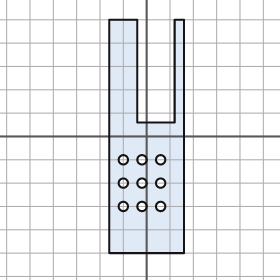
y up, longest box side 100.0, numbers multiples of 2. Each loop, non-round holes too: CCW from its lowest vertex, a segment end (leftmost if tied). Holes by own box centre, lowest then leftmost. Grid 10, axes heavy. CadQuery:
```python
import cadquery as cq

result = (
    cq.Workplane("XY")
    .moveTo(-16.0, -50.0)
    .lineTo(16.0, -50.0)
    .lineTo(16.0, 50.0)
    .lineTo(12.0, 50.0)
    .lineTo(12.0, 6.0)
    .lineTo(-4.0, 6.0)
    .lineTo(-4.0, 50.0)
    .lineTo(-16.0, 50.0)
    .close()
    .moveTo(-10.0, -30.0)
    .circle(2.0)
    .moveTo(-2.0, -30.0)
    .circle(2.0)
    .moveTo(6.0, -30.0)
    .circle(2.0)
    .moveTo(-10.0, -20.0)
    .circle(2.0)
    .moveTo(-2.0, -20.0)
    .circle(2.0)
    .moveTo(6.0, -20.0)
    .circle(2.0)
    .moveTo(-10.0, -10.0)
    .circle(2.0)
    .moveTo(-2.0, -10.0)
    .circle(2.0)
    .moveTo(6.0, -10.0)
    .circle(2.0)
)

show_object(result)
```